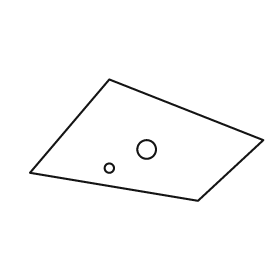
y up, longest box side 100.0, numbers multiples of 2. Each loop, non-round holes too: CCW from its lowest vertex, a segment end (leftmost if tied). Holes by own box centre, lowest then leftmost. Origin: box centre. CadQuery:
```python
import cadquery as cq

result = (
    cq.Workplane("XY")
    .moveTo(22.0, -26.0)
    .lineTo(50.0, 0.0)
    .lineTo(-16.0, 26.0)
    .lineTo(-50.0, -14.0)
    .close()
    .moveTo(-16.0, -12.0)
    .circle(2.0)
    .moveTo(0.0, -4.0)
    .circle(4.0)
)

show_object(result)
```